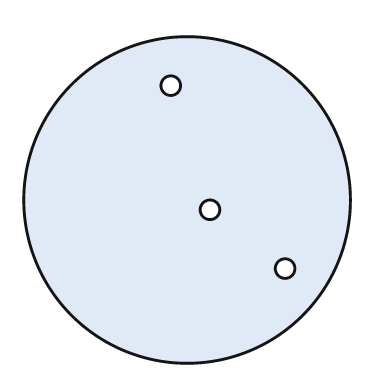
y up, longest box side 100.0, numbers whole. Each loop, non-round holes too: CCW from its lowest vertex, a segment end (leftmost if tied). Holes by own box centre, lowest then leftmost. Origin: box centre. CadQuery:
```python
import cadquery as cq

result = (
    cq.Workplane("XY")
    .moveTo(0.0, 0.0)
    .circle(50.0)
    .moveTo(30.0, -21.0)
    .circle(3.0)
    .moveTo(7.0, -3.0)
    .circle(3.0)
    .moveTo(-5.0, 35.0)
    .circle(3.0)
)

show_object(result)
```